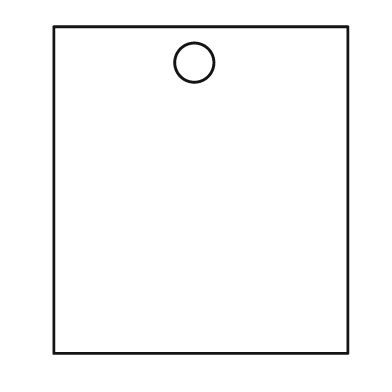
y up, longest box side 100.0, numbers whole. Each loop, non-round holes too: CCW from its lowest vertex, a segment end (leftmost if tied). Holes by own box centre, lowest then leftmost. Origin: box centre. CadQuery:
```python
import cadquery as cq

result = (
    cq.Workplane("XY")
    .moveTo(-45.0, -50.0)
    .lineTo(45.0, -50.0)
    .lineTo(45.0, 50.0)
    .lineTo(-45.0, 50.0)
    .close()
    .moveTo(-2.0, 39.0)
    .circle(6.0)
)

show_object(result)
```